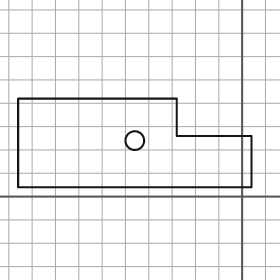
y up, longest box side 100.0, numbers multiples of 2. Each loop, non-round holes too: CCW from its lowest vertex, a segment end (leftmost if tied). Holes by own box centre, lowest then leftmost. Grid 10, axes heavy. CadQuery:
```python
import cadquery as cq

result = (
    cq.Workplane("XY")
    .moveTo(-96.0, 4.0)
    .lineTo(4.0, 4.0)
    .lineTo(4.0, 26.0)
    .lineTo(-28.0, 26.0)
    .lineTo(-28.0, 42.0)
    .lineTo(-96.0, 42.0)
    .close()
    .moveTo(-46.0, 24.0)
    .circle(4.0)
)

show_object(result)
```